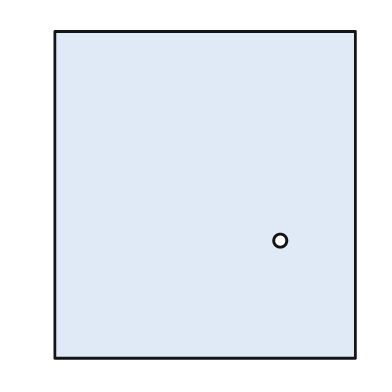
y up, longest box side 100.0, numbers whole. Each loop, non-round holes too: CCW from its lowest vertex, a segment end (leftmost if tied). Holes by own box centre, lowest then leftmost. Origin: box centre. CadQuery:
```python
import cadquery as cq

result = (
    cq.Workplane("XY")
    .moveTo(-46.0, -50.0)
    .lineTo(46.0, -50.0)
    .lineTo(46.0, 50.0)
    .lineTo(-46.0, 50.0)
    .close()
    .moveTo(23.0, -14.0)
    .circle(2.0)
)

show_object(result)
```